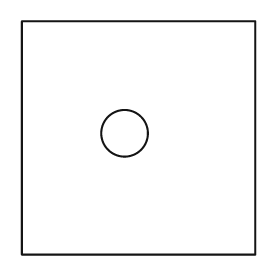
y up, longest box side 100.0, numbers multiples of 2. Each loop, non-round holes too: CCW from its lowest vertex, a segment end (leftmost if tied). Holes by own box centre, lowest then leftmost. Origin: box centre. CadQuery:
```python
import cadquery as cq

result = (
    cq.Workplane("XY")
    .moveTo(-50.0, -50.0)
    .lineTo(50.0, -50.0)
    .lineTo(50.0, 50.0)
    .lineTo(-50.0, 50.0)
    .close()
    .moveTo(-6.0, 2.0)
    .circle(10.0)
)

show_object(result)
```